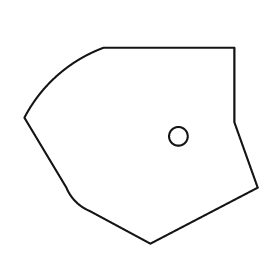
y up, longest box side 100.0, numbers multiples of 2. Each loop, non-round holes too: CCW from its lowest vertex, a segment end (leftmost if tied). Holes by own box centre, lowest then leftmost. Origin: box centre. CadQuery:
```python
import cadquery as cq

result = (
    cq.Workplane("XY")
    .moveTo(4.0, -42.0)
    .lineTo(50.0, -18.0)
    .lineTo(40.0, 10.0)
    .lineTo(40.0, 42.0)
    .lineTo(-16.0, 42.0)
    .threePointArc((-36.0, 30.0), (-50.0, 12.0))
    .lineTo(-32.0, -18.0)
    .threePointArc((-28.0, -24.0), (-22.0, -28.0))
    .close()
    .moveTo(16.0, 4.0)
    .circle(4.0)
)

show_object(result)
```